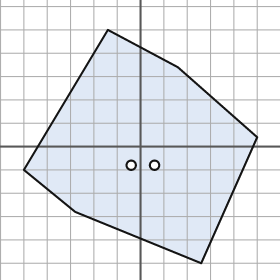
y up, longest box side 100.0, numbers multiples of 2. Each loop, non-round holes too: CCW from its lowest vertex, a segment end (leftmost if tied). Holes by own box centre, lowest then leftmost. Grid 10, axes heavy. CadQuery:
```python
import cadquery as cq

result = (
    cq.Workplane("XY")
    .moveTo(26.0, -50.0)
    .lineTo(50.0, 4.0)
    .lineTo(16.0, 34.0)
    .lineTo(-14.0, 50.0)
    .lineTo(-50.0, -10.0)
    .lineTo(-28.0, -28.0)
    .close()
    .moveTo(-4.0, -8.0)
    .circle(2.0)
    .moveTo(6.0, -8.0)
    .circle(2.0)
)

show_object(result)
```